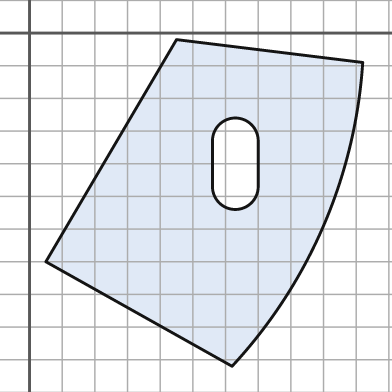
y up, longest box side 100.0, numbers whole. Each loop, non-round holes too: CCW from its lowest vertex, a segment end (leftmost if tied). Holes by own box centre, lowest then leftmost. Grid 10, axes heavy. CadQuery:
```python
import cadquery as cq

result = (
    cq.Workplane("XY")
    .moveTo(62.0, -102.0)
    .threePointArc((90.0, -59.0), (102.0, -9.0))
    .lineTo(45.0, -2.0)
    .lineTo(5.0, -70.0)
    .close()
    .moveTo(56.0, -47.0)
    .threePointArc((63.0, -54.0), (70.0, -47.0))
    .lineTo(70.0, -33.0)
    .threePointArc((63.0, -26.0), (56.0, -33.0))
    .close()
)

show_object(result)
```